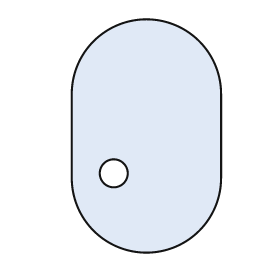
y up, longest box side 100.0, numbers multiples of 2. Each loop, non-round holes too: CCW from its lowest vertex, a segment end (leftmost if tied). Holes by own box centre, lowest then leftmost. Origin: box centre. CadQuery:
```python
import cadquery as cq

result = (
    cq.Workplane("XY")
    .moveTo(-32.0, -18.0)
    .threePointArc((0.0, -50.0), (32.0, -18.0))
    .lineTo(32.0, 18.0)
    .threePointArc((0.0, 50.0), (-32.0, 18.0))
    .close()
    .moveTo(-14.0, -16.0)
    .circle(6.0)
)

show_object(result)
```